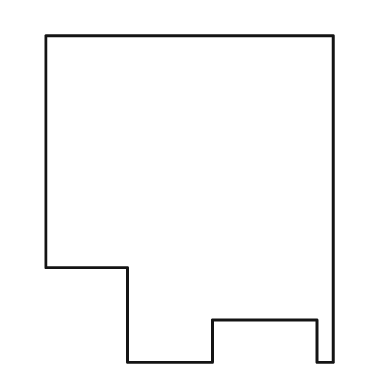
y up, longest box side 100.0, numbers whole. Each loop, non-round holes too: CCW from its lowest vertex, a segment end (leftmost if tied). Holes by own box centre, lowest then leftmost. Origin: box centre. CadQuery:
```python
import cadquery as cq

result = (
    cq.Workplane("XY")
    .moveTo(-19.0, -50.0)
    .lineTo(7.0, -50.0)
    .lineTo(7.0, -37.0)
    .lineTo(39.0, -37.0)
    .lineTo(39.0, -50.0)
    .lineTo(44.0, -50.0)
    .lineTo(44.0, 50.0)
    .lineTo(-44.0, 50.0)
    .lineTo(-44.0, -21.0)
    .lineTo(-19.0, -21.0)
    .close()
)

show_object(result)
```